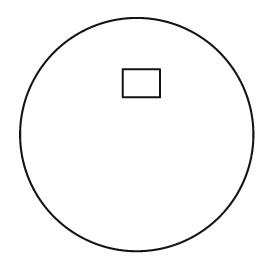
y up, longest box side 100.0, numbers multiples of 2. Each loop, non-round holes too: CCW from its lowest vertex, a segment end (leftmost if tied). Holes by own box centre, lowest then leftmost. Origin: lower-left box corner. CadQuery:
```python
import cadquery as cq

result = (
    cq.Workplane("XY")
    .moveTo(50.0, 50.0)
    .circle(50.0)
    .moveTo(44.0, 66.0)
    .lineTo(60.0, 66.0)
    .lineTo(60.0, 78.0)
    .lineTo(44.0, 78.0)
    .close()
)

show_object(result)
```